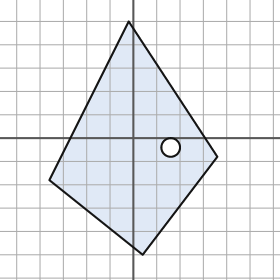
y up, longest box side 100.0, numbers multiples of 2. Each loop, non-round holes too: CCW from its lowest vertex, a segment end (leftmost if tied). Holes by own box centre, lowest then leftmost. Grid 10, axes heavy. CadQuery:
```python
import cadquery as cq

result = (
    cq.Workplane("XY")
    .moveTo(4.0, -50.0)
    .lineTo(36.0, -8.0)
    .lineTo(-2.0, 50.0)
    .lineTo(-36.0, -18.0)
    .close()
    .moveTo(16.0, -4.0)
    .circle(4.0)
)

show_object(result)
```